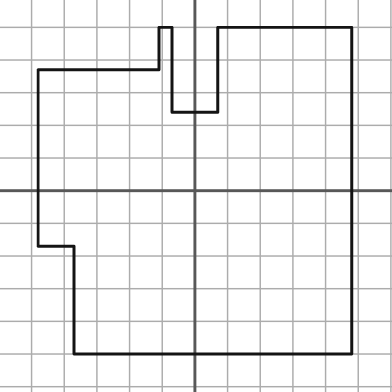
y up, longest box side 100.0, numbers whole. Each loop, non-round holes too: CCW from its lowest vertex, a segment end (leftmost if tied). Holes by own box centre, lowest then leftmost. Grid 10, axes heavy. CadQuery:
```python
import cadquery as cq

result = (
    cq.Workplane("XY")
    .moveTo(-37.0, -50.0)
    .lineTo(48.0, -50.0)
    .lineTo(48.0, 50.0)
    .lineTo(7.0, 50.0)
    .lineTo(7.0, 24.0)
    .lineTo(-7.0, 24.0)
    .lineTo(-7.0, 50.0)
    .lineTo(-11.0, 50.0)
    .lineTo(-11.0, 37.0)
    .lineTo(-48.0, 37.0)
    .lineTo(-48.0, -17.0)
    .lineTo(-37.0, -17.0)
    .close()
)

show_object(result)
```